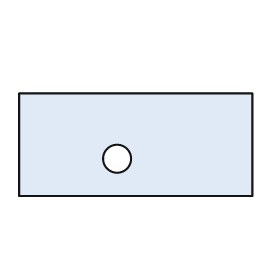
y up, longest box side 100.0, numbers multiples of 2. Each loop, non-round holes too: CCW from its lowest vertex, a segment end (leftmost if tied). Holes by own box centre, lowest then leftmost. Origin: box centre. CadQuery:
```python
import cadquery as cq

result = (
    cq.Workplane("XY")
    .moveTo(-50.0, -22.0)
    .lineTo(50.0, -22.0)
    .lineTo(50.0, 22.0)
    .lineTo(-50.0, 22.0)
    .close()
    .moveTo(-8.0, -6.0)
    .circle(6.0)
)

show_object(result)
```